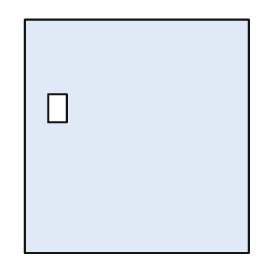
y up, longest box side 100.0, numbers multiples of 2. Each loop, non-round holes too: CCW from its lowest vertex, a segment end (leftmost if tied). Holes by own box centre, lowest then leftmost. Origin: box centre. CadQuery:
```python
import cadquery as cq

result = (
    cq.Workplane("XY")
    .moveTo(-48.0, -50.0)
    .lineTo(48.0, -50.0)
    .lineTo(48.0, 50.0)
    .lineTo(-48.0, 50.0)
    .close()
    .moveTo(-38.0, 6.0)
    .lineTo(-30.0, 6.0)
    .lineTo(-30.0, 18.0)
    .lineTo(-38.0, 18.0)
    .close()
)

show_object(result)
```